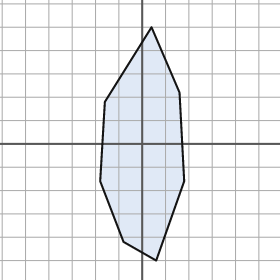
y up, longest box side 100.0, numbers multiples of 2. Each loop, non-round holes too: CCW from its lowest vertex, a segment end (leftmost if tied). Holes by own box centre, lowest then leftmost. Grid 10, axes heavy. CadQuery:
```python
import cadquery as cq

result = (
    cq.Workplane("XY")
    .moveTo(6.0, -50.0)
    .lineTo(18.0, -16.0)
    .lineTo(16.0, 22.0)
    .lineTo(4.0, 50.0)
    .lineTo(-16.0, 18.0)
    .lineTo(-18.0, -16.0)
    .lineTo(-8.0, -42.0)
    .close()
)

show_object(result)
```